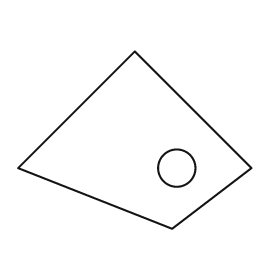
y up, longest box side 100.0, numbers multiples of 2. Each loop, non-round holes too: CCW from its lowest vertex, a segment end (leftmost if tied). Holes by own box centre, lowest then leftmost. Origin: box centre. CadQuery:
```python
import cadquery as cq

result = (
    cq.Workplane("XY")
    .moveTo(16.0, -38.0)
    .lineTo(50.0, -12.0)
    .lineTo(0.0, 38.0)
    .lineTo(-50.0, -12.0)
    .close()
    .moveTo(18.0, -12.0)
    .circle(8.0)
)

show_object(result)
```